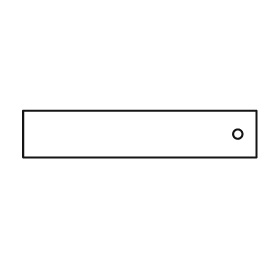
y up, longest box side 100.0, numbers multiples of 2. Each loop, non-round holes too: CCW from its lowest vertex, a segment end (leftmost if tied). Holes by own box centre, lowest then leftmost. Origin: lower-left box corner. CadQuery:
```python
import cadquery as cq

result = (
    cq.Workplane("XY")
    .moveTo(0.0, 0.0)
    .lineTo(100.0, 0.0)
    .lineTo(100.0, 20.0)
    .lineTo(0.0, 20.0)
    .close()
    .moveTo(92.0, 10.0)
    .circle(2.0)
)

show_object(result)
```